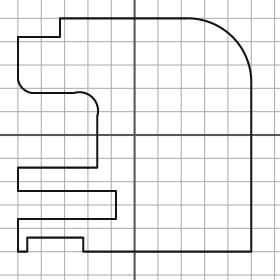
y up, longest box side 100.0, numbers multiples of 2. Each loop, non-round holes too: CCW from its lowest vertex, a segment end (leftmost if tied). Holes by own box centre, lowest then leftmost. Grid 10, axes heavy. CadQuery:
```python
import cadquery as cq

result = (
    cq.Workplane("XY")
    .moveTo(-50.0, -50.0)
    .lineTo(-46.0, -50.0)
    .lineTo(-46.0, -44.0)
    .lineTo(-22.0, -44.0)
    .lineTo(-22.0, -50.0)
    .lineTo(50.0, -50.0)
    .lineTo(50.0, 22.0)
    .threePointArc((42.0, 42.0), (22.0, 50.0))
    .lineTo(-32.0, 50.0)
    .lineTo(-32.0, 42.0)
    .lineTo(-50.0, 42.0)
    .lineTo(-50.0, 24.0)
    .threePointArc((-48.0, 20.0), (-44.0, 18.0))
    .lineTo(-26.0, 18.0)
    .threePointArc((-18.0, 16.0), (-16.0, 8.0))
    .lineTo(-16.0, -14.0)
    .lineTo(-50.0, -14.0)
    .lineTo(-50.0, -24.0)
    .lineTo(-8.0, -24.0)
    .lineTo(-8.0, -36.0)
    .lineTo(-50.0, -36.0)
    .close()
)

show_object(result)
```